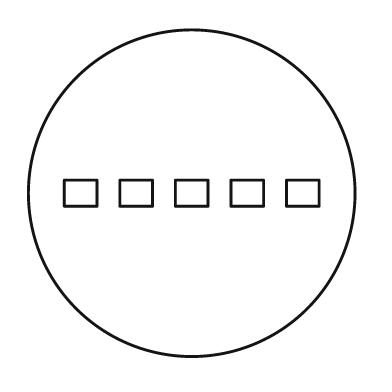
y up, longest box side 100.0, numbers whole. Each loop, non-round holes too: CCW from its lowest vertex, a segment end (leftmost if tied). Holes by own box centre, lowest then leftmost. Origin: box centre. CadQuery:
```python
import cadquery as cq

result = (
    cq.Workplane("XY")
    .moveTo(0.0, 0.0)
    .circle(50.0)
    .moveTo(-39.0, -4.0)
    .lineTo(-29.0, -4.0)
    .lineTo(-29.0, 4.0)
    .lineTo(-39.0, 4.0)
    .close()
    .moveTo(-22.0, -4.0)
    .lineTo(-12.0, -4.0)
    .lineTo(-12.0, 4.0)
    .lineTo(-22.0, 4.0)
    .close()
    .moveTo(-5.0, -4.0)
    .lineTo(5.0, -4.0)
    .lineTo(5.0, 4.0)
    .lineTo(-5.0, 4.0)
    .close()
    .moveTo(12.0, -4.0)
    .lineTo(22.0, -4.0)
    .lineTo(22.0, 4.0)
    .lineTo(12.0, 4.0)
    .close()
    .moveTo(29.0, -4.0)
    .lineTo(39.0, -4.0)
    .lineTo(39.0, 4.0)
    .lineTo(29.0, 4.0)
    .close()
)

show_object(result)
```